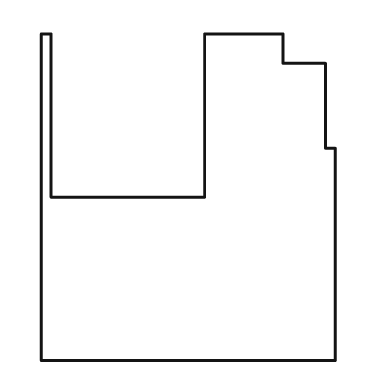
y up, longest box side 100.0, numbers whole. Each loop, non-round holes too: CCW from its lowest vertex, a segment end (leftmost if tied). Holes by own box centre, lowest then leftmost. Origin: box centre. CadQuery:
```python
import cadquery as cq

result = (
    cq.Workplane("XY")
    .moveTo(-45.0, -50.0)
    .lineTo(45.0, -50.0)
    .lineTo(45.0, 15.0)
    .lineTo(42.0, 15.0)
    .lineTo(42.0, 41.0)
    .lineTo(29.0, 41.0)
    .lineTo(29.0, 50.0)
    .lineTo(5.0, 50.0)
    .lineTo(5.0, 0.0)
    .lineTo(-42.0, 0.0)
    .lineTo(-42.0, 50.0)
    .lineTo(-45.0, 50.0)
    .close()
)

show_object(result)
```